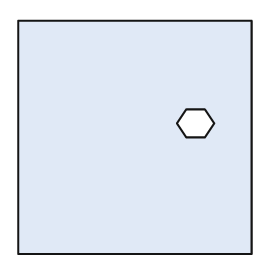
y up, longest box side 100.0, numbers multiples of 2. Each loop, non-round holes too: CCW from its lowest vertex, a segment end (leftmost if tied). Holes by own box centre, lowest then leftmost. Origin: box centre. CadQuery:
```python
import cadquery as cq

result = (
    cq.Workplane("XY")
    .moveTo(-50.0, -50.0)
    .lineTo(50.0, -50.0)
    .lineTo(50.0, 50.0)
    .lineTo(-50.0, 50.0)
    .close()
    .moveTo(22.0, 0.0)
    .lineTo(30.0, 0.0)
    .lineTo(34.0, 6.0)
    .lineTo(30.0, 12.0)
    .lineTo(22.0, 12.0)
    .lineTo(18.0, 6.0)
    .close()
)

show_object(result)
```